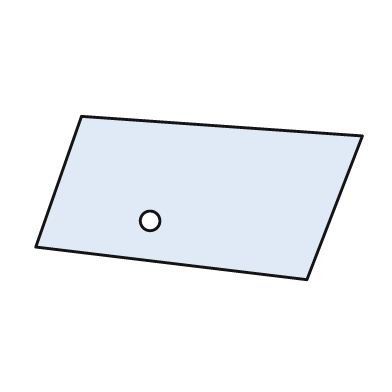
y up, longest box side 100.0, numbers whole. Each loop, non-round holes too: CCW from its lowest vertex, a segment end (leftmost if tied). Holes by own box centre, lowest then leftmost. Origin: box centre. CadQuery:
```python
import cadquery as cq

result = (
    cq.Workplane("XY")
    .moveTo(33.0, -25.0)
    .lineTo(50.0, 19.0)
    .lineTo(-36.0, 25.0)
    .lineTo(-50.0, -15.0)
    .close()
    .moveTo(-15.0, -7.0)
    .circle(3.0)
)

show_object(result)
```